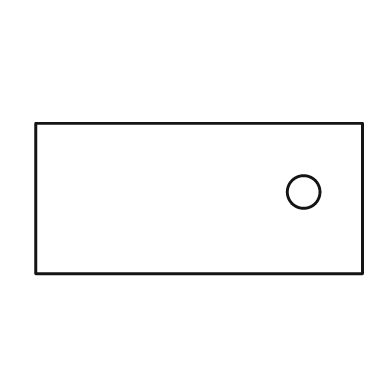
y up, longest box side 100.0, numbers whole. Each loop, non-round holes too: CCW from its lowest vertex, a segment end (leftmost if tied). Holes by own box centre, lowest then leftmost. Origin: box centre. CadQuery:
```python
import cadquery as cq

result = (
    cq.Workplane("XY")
    .moveTo(-50.0, -23.0)
    .lineTo(50.0, -23.0)
    .lineTo(50.0, 23.0)
    .lineTo(-50.0, 23.0)
    .close()
    .moveTo(32.0, 2.0)
    .circle(5.0)
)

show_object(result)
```